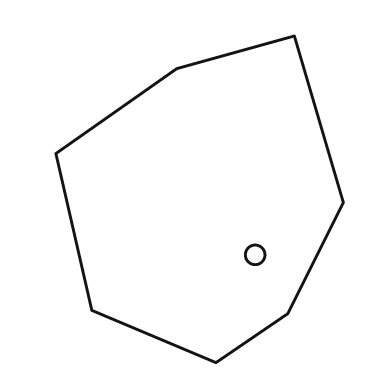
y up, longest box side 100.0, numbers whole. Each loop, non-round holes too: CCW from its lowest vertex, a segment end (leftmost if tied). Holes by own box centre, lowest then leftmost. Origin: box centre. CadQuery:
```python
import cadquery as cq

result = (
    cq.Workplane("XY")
    .moveTo(5.0, -50.0)
    .lineTo(27.0, -35.0)
    .lineTo(44.0, -1.0)
    .lineTo(29.0, 50.0)
    .lineTo(-7.0, 40.0)
    .lineTo(-44.0, 14.0)
    .lineTo(-33.0, -34.0)
    .close()
    .moveTo(17.0, -17.0)
    .circle(3.0)
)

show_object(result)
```